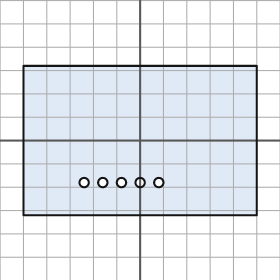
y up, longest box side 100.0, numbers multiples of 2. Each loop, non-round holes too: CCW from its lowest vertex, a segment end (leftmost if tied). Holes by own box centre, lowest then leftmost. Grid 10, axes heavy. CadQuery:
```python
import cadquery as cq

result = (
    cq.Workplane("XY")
    .moveTo(-50.0, -32.0)
    .lineTo(50.0, -32.0)
    .lineTo(50.0, 32.0)
    .lineTo(-50.0, 32.0)
    .close()
    .moveTo(-24.0, -18.0)
    .circle(2.0)
    .moveTo(-16.0, -18.0)
    .circle(2.0)
    .moveTo(-8.0, -18.0)
    .circle(2.0)
    .moveTo(0.0, -18.0)
    .circle(2.0)
    .moveTo(8.0, -18.0)
    .circle(2.0)
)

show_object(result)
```